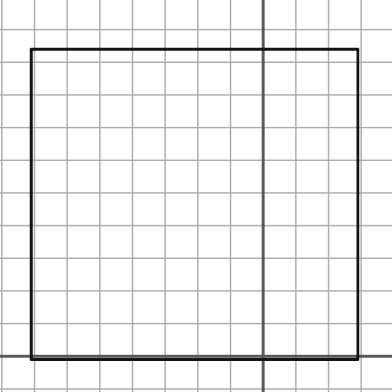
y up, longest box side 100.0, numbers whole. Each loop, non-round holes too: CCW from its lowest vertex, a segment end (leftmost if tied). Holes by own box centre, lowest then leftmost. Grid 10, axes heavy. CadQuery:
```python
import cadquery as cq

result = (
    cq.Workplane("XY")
    .moveTo(-71.0, -1.0)
    .lineTo(29.0, -1.0)
    .lineTo(29.0, 94.0)
    .lineTo(-71.0, 94.0)
    .close()
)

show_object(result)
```